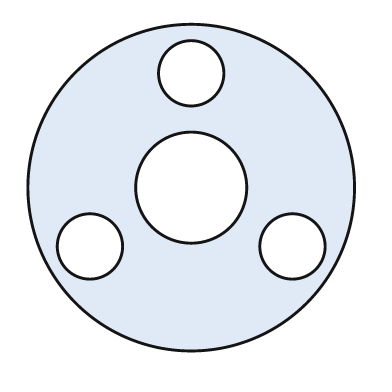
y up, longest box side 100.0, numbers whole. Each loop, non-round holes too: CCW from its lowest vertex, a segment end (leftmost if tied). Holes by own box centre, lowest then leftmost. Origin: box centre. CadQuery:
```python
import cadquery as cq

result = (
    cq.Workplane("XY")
    .moveTo(0.0, 0.0)
    .circle(50.0)
    .moveTo(-31.0, -18.0)
    .circle(10.0)
    .moveTo(31.0, -18.0)
    .circle(10.0)
    .moveTo(0.0, 0.0)
    .circle(17.0)
    .moveTo(0.0, 35.0)
    .circle(10.0)
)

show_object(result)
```